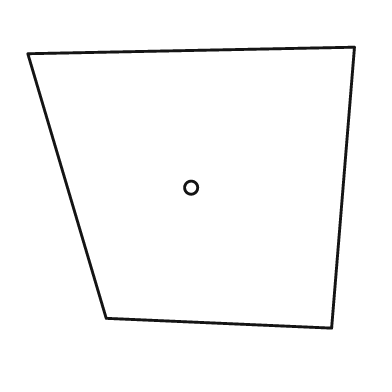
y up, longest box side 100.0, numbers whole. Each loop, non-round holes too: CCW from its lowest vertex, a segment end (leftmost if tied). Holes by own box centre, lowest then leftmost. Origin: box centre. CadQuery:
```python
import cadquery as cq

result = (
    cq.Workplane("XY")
    .moveTo(43.0, -43.0)
    .lineTo(50.0, 43.0)
    .lineTo(-50.0, 41.0)
    .lineTo(-26.0, -40.0)
    .close()
    .moveTo(0.0, 0.0)
    .circle(2.0)
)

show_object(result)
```